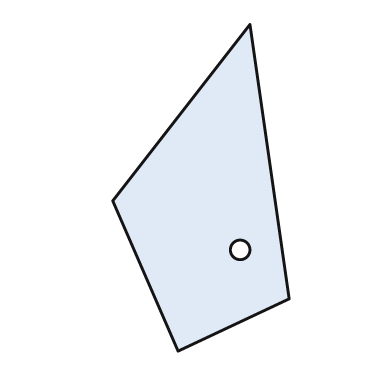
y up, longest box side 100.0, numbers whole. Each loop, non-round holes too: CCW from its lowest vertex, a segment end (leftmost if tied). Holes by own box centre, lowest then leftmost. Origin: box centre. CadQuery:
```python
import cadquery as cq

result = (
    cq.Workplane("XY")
    .moveTo(-7.0, -50.0)
    .lineTo(27.0, -34.0)
    .lineTo(15.0, 50.0)
    .lineTo(-27.0, -4.0)
    .close()
    .moveTo(12.0, -19.0)
    .circle(3.0)
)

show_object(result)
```